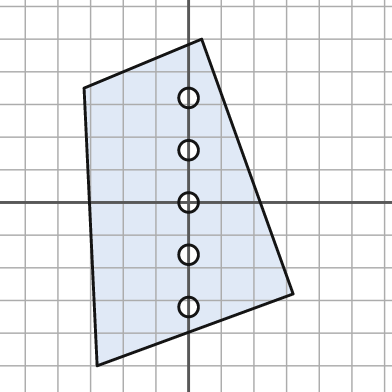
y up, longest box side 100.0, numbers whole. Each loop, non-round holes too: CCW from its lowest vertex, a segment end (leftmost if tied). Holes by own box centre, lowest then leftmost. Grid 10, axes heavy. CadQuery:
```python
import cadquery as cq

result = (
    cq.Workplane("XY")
    .moveTo(-28.0, -50.0)
    .lineTo(32.0, -28.0)
    .lineTo(4.0, 50.0)
    .lineTo(-32.0, 35.0)
    .close()
    .moveTo(0.0, -32.0)
    .circle(3.0)
    .moveTo(0.0, -16.0)
    .circle(3.0)
    .moveTo(0.0, 0.0)
    .circle(3.0)
    .moveTo(0.0, 16.0)
    .circle(3.0)
    .moveTo(0.0, 32.0)
    .circle(3.0)
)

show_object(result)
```